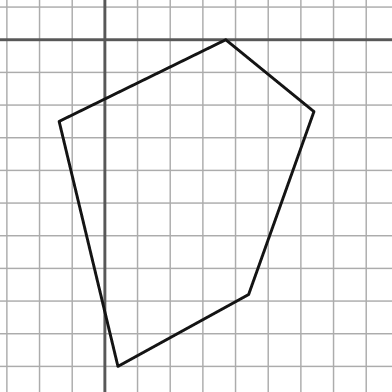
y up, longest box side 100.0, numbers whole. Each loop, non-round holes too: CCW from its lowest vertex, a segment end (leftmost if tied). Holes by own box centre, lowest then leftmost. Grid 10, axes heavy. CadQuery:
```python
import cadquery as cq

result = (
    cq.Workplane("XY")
    .moveTo(4.0, -100.0)
    .lineTo(44.0, -78.0)
    .lineTo(64.0, -22.0)
    .lineTo(37.0, 0.0)
    .lineTo(-14.0, -25.0)
    .close()
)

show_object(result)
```